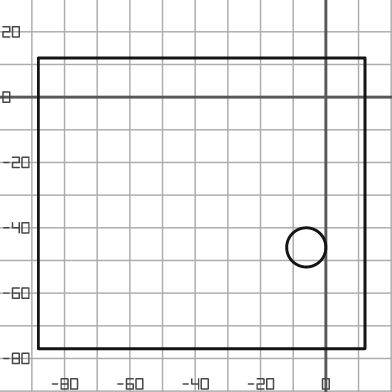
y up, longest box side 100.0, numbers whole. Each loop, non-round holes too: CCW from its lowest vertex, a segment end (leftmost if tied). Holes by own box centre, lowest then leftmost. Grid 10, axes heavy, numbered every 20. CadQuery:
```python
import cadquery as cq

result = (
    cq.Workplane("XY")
    .moveTo(-88.0, -77.0)
    .lineTo(12.0, -77.0)
    .lineTo(12.0, 12.0)
    .lineTo(-88.0, 12.0)
    .close()
    .moveTo(-6.0, -46.0)
    .circle(6.0)
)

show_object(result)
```